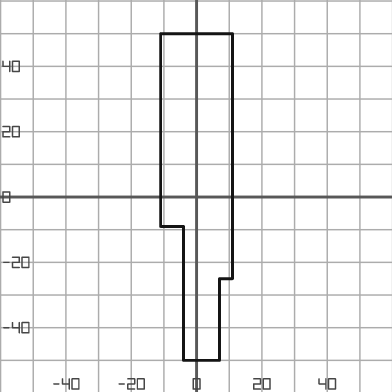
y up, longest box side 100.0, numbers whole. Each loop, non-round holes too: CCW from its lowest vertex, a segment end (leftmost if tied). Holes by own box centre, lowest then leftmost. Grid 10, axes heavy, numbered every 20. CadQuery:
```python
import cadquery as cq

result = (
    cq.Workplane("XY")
    .moveTo(-4.0, -50.0)
    .lineTo(7.0, -50.0)
    .lineTo(7.0, -25.0)
    .lineTo(11.0, -25.0)
    .lineTo(11.0, 50.0)
    .lineTo(-11.0, 50.0)
    .lineTo(-11.0, -9.0)
    .lineTo(-4.0, -9.0)
    .close()
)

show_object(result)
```